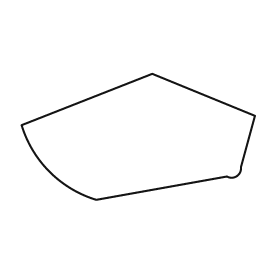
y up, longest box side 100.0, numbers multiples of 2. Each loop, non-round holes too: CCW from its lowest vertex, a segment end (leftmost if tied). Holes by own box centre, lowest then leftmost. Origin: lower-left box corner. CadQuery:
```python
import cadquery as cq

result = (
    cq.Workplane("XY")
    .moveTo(32.0, 0.0)
    .lineTo(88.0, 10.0)
    .threePointArc((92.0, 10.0), (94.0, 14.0))
    .lineTo(100.0, 36.0)
    .lineTo(56.0, 54.0)
    .lineTo(0.0, 32.0)
    .threePointArc((12.0, 12.0), (32.0, 0.0))
    .close()
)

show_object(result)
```